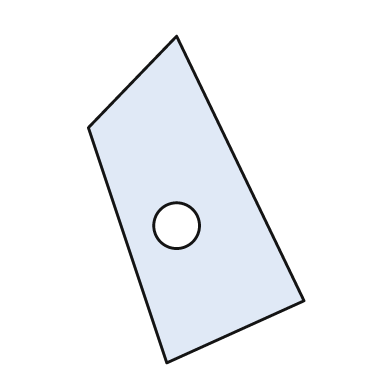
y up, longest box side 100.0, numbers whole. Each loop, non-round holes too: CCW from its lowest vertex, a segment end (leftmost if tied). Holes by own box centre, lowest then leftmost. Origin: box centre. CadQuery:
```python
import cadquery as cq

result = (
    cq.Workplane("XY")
    .moveTo(-9.0, -50.0)
    .lineTo(33.0, -31.0)
    .lineTo(-6.0, 50.0)
    .lineTo(-33.0, 22.0)
    .close()
    .moveTo(-6.0, -8.0)
    .circle(7.0)
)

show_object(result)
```